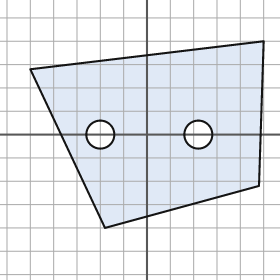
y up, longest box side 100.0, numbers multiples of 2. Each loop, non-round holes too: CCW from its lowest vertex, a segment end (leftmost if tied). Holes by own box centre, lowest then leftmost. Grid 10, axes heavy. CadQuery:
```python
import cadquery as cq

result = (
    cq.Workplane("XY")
    .moveTo(-18.0, -40.0)
    .lineTo(48.0, -22.0)
    .lineTo(50.0, 40.0)
    .lineTo(-50.0, 28.0)
    .close()
    .moveTo(-20.0, 0.0)
    .circle(6.0)
    .moveTo(22.0, 0.0)
    .circle(6.0)
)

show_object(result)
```